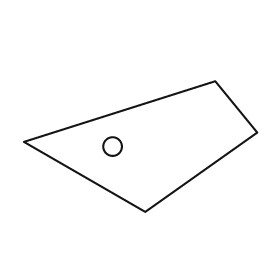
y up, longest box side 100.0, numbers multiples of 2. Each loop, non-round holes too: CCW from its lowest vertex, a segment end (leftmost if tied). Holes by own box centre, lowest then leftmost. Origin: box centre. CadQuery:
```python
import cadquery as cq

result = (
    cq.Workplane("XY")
    .moveTo(2.0, -28.0)
    .lineTo(50.0, 6.0)
    .lineTo(32.0, 28.0)
    .lineTo(-50.0, 2.0)
    .close()
    .moveTo(-12.0, 0.0)
    .circle(4.0)
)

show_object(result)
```